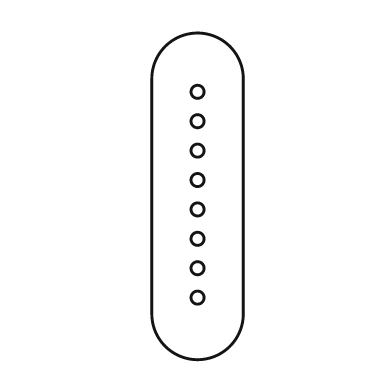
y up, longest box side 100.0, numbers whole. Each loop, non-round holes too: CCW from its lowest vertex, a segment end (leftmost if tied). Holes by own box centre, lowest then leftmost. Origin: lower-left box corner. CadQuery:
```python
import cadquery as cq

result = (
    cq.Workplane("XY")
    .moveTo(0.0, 14.0)
    .threePointArc((14.0, 0.0), (28.0, 14.0))
    .lineTo(28.0, 86.0)
    .threePointArc((14.0, 100.0), (0.0, 86.0))
    .close()
    .moveTo(14.0, 19.0)
    .circle(2.0)
    .moveTo(14.0, 28.0)
    .circle(2.0)
    .moveTo(14.0, 37.0)
    .circle(2.0)
    .moveTo(14.0, 46.0)
    .circle(2.0)
    .moveTo(14.0, 55.0)
    .circle(2.0)
    .moveTo(14.0, 64.0)
    .circle(2.0)
    .moveTo(14.0, 73.0)
    .circle(2.0)
    .moveTo(14.0, 82.0)
    .circle(2.0)
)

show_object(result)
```